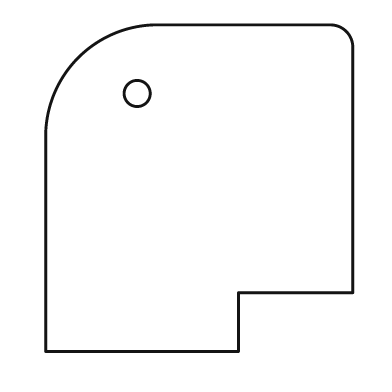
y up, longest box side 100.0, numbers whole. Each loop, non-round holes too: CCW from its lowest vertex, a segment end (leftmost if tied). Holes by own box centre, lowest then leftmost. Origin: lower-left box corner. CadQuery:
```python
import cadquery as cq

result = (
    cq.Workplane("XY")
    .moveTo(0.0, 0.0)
    .lineTo(59.0, 0.0)
    .lineTo(59.0, 18.0)
    .lineTo(94.0, 18.0)
    .lineTo(94.0, 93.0)
    .threePointArc((92.0, 98.0), (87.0, 100.0))
    .lineTo(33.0, 100.0)
    .threePointArc((10.0, 90.0), (0.0, 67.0))
    .close()
    .moveTo(28.0, 79.0)
    .circle(4.0)
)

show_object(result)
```